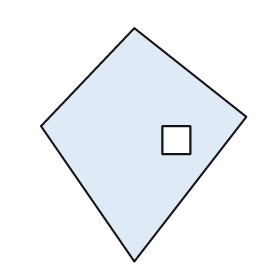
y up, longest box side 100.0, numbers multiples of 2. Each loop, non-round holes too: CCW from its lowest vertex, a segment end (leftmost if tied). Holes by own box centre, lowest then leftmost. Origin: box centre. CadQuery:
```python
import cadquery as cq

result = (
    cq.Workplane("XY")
    .moveTo(-4.0, -50.0)
    .lineTo(44.0, 12.0)
    .lineTo(-4.0, 50.0)
    .lineTo(-44.0, 8.0)
    .close()
    .moveTo(8.0, -4.0)
    .lineTo(20.0, -4.0)
    .lineTo(20.0, 8.0)
    .lineTo(8.0, 8.0)
    .close()
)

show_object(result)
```